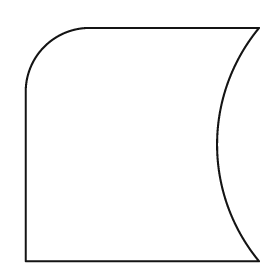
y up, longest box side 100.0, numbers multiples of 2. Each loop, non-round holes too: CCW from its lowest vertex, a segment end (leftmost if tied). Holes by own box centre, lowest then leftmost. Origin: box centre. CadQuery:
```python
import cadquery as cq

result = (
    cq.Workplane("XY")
    .moveTo(-50.0, -50.0)
    .lineTo(50.0, -50.0)
    .threePointArc((32.0, 0.0), (50.0, 50.0))
    .lineTo(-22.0, 50.0)
    .threePointArc((-42.0, 42.0), (-50.0, 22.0))
    .close()
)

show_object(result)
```